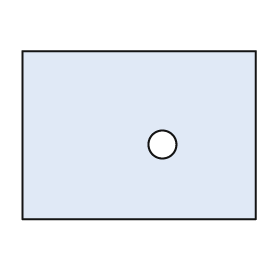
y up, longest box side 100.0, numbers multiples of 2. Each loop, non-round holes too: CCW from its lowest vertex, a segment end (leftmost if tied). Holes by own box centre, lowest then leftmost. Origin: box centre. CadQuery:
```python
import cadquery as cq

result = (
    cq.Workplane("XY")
    .moveTo(-50.0, -36.0)
    .lineTo(50.0, -36.0)
    .lineTo(50.0, 36.0)
    .lineTo(-50.0, 36.0)
    .close()
    .moveTo(10.0, -4.0)
    .circle(6.0)
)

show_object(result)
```